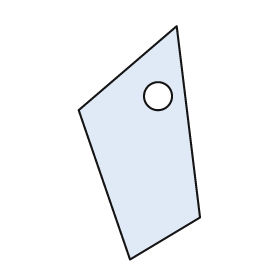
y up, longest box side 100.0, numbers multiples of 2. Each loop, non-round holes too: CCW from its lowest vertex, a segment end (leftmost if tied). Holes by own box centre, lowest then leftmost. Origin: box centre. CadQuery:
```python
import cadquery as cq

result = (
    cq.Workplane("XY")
    .moveTo(-4.0, -50.0)
    .lineTo(26.0, -32.0)
    .lineTo(16.0, 50.0)
    .lineTo(-26.0, 14.0)
    .close()
    .moveTo(8.0, 20.0)
    .circle(6.0)
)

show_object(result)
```